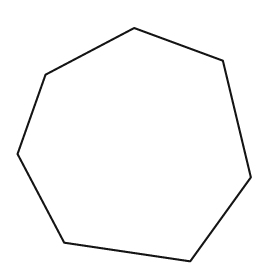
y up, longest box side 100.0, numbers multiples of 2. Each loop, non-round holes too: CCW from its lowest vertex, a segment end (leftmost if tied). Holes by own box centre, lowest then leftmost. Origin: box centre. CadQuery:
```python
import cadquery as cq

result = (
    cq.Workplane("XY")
    .moveTo(24.0, -50.0)
    .lineTo(50.0, -14.0)
    .lineTo(38.0, 36.0)
    .lineTo(0.0, 50.0)
    .lineTo(-38.0, 30.0)
    .lineTo(-50.0, -4.0)
    .lineTo(-30.0, -42.0)
    .close()
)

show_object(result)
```